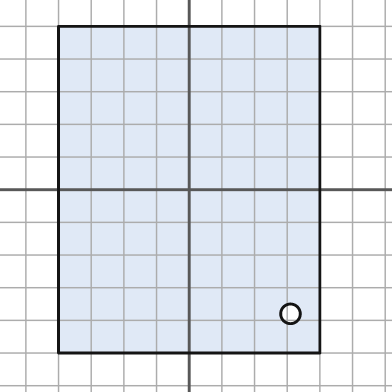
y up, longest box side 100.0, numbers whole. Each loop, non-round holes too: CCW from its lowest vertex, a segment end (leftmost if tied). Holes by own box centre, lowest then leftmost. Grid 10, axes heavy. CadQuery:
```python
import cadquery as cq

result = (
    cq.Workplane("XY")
    .moveTo(-40.0, -50.0)
    .lineTo(40.0, -50.0)
    .lineTo(40.0, 50.0)
    .lineTo(-40.0, 50.0)
    .close()
    .moveTo(31.0, -38.0)
    .circle(3.0)
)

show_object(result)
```